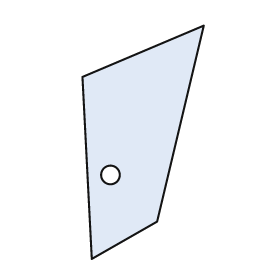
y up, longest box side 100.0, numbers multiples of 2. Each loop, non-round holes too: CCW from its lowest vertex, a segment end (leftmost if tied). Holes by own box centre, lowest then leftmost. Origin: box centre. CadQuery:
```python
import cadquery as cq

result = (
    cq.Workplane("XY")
    .moveTo(-22.0, -50.0)
    .lineTo(6.0, -34.0)
    .lineTo(26.0, 50.0)
    .lineTo(-26.0, 28.0)
    .close()
    .moveTo(-14.0, -14.0)
    .circle(4.0)
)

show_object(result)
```